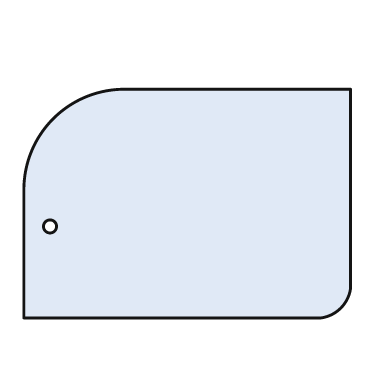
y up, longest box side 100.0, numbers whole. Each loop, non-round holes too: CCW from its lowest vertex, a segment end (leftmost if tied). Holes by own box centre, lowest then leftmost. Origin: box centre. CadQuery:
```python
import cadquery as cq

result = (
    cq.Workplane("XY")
    .moveTo(-50.0, -35.0)
    .lineTo(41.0, -35.0)
    .threePointArc((47.0, -32.0), (50.0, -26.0))
    .lineTo(50.0, 35.0)
    .lineTo(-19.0, 35.0)
    .threePointArc((-41.0, 26.0), (-50.0, 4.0))
    .close()
    .moveTo(-42.0, -7.0)
    .circle(2.0)
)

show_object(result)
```